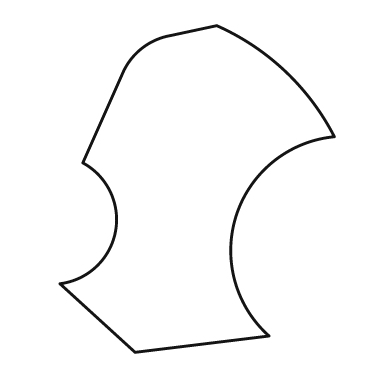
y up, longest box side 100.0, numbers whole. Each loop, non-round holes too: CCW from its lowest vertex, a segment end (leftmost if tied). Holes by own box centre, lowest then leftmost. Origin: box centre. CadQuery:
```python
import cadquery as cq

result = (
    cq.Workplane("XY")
    .moveTo(-19.0, -50.0)
    .lineTo(22.0, -45.0)
    .threePointArc((12.0, -8.0), (42.0, 16.0))
    .threePointArc((27.0, 36.0), (6.0, 50.0))
    .lineTo(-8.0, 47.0)
    .threePointArc((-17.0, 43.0), (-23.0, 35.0))
    .lineTo(-35.0, 8.0)
    .threePointArc((-25.0, -13.0), (-42.0, -29.0))
    .close()
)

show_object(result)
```